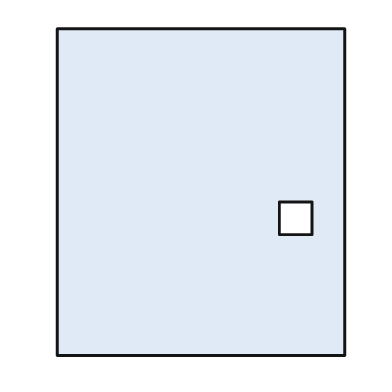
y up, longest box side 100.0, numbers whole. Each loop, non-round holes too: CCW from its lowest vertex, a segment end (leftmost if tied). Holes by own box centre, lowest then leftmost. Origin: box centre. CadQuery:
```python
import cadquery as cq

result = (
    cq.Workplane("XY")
    .moveTo(-44.0, -50.0)
    .lineTo(44.0, -50.0)
    .lineTo(44.0, 50.0)
    .lineTo(-44.0, 50.0)
    .close()
    .moveTo(24.0, -13.0)
    .lineTo(34.0, -13.0)
    .lineTo(34.0, -3.0)
    .lineTo(24.0, -3.0)
    .close()
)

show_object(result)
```